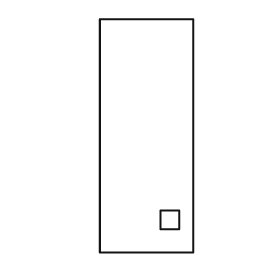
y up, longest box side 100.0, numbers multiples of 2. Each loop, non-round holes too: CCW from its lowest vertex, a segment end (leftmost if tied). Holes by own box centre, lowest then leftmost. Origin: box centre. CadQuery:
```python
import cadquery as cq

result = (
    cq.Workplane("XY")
    .moveTo(-20.0, -50.0)
    .lineTo(20.0, -50.0)
    .lineTo(20.0, 50.0)
    .lineTo(-20.0, 50.0)
    .close()
    .moveTo(6.0, -40.0)
    .lineTo(14.0, -40.0)
    .lineTo(14.0, -32.0)
    .lineTo(6.0, -32.0)
    .close()
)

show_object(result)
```